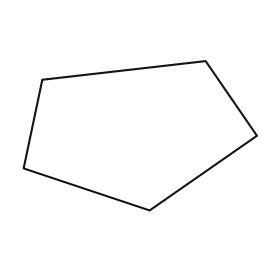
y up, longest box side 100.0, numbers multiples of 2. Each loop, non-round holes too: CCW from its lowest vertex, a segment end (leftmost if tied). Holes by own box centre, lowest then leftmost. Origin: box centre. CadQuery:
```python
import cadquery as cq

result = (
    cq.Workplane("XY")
    .moveTo(4.0, -32.0)
    .lineTo(50.0, 0.0)
    .lineTo(28.0, 32.0)
    .lineTo(-42.0, 24.0)
    .lineTo(-50.0, -14.0)
    .close()
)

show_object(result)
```